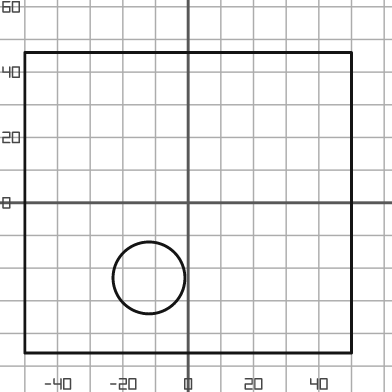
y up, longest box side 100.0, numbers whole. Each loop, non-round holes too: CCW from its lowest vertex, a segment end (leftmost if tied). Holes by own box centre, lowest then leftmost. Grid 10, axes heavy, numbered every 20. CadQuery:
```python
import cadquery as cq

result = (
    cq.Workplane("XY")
    .moveTo(-50.0, -46.0)
    .lineTo(50.0, -46.0)
    .lineTo(50.0, 46.0)
    .lineTo(-50.0, 46.0)
    .close()
    .moveTo(-12.0, -23.0)
    .circle(11.0)
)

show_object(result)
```